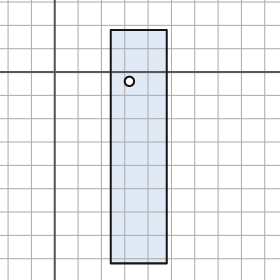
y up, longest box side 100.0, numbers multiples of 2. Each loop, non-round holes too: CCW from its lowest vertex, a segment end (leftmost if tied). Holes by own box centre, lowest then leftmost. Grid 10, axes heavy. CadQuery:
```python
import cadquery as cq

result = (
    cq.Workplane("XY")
    .moveTo(24.0, -82.0)
    .lineTo(48.0, -82.0)
    .lineTo(48.0, 18.0)
    .lineTo(24.0, 18.0)
    .close()
    .moveTo(32.0, -4.0)
    .circle(2.0)
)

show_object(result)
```